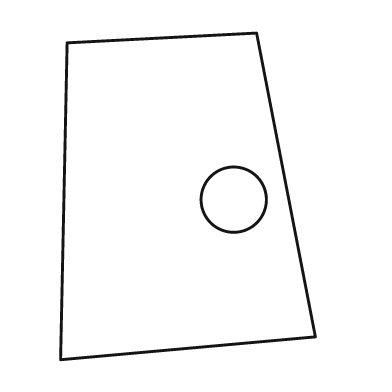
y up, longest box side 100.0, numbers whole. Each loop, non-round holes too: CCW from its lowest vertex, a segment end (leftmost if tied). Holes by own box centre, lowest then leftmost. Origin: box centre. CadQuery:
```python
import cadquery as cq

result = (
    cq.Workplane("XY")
    .moveTo(-39.0, -50.0)
    .lineTo(39.0, -43.0)
    .lineTo(21.0, 50.0)
    .lineTo(-37.0, 47.0)
    .close()
    .moveTo(14.0, -1.0)
    .circle(10.0)
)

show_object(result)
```